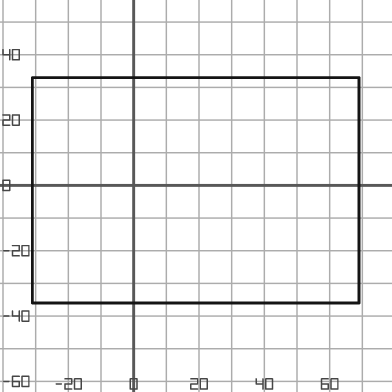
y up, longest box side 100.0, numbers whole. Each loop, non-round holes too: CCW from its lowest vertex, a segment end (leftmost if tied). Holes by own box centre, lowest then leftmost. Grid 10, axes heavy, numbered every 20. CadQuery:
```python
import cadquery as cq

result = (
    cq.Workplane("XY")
    .moveTo(-31.0, -36.0)
    .lineTo(69.0, -36.0)
    .lineTo(69.0, 33.0)
    .lineTo(-31.0, 33.0)
    .close()
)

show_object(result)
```